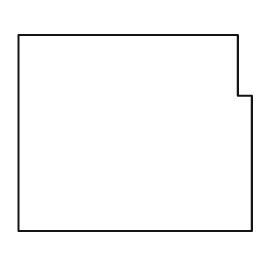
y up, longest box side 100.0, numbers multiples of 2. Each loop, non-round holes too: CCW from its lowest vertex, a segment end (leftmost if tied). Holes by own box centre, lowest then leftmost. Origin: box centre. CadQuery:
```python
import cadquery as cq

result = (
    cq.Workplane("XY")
    .moveTo(-50.0, -42.0)
    .lineTo(50.0, -42.0)
    .lineTo(50.0, 16.0)
    .lineTo(44.0, 16.0)
    .lineTo(44.0, 42.0)
    .lineTo(-50.0, 42.0)
    .close()
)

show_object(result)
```